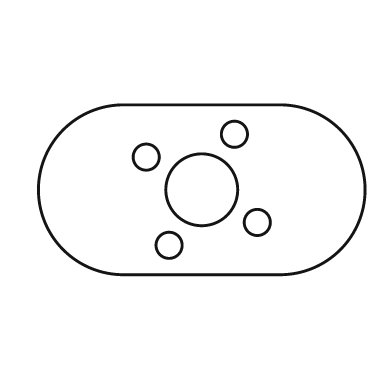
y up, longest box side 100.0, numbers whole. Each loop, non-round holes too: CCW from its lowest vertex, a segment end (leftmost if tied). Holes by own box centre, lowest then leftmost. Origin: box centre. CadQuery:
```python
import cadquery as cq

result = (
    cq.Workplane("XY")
    .moveTo(-24.0, -26.0)
    .lineTo(24.0, -26.0)
    .threePointArc((50.0, 0.0), (24.0, 26.0))
    .lineTo(-24.0, 26.0)
    .threePointArc((-50.0, 0.0), (-24.0, -26.0))
    .close()
    .moveTo(-10.0, -17.0)
    .circle(4.0)
    .moveTo(17.0, -10.0)
    .circle(4.0)
    .moveTo(0.0, 0.0)
    .circle(11.0)
    .moveTo(-17.0, 10.0)
    .circle(4.0)
    .moveTo(10.0, 17.0)
    .circle(4.0)
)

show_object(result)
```